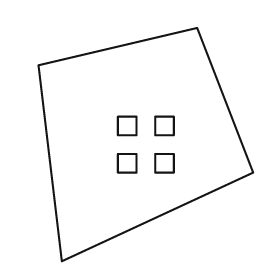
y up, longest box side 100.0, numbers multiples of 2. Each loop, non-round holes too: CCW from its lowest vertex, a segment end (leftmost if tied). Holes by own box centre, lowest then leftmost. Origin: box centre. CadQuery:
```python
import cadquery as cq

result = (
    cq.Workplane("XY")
    .moveTo(-36.0, -50.0)
    .lineTo(46.0, -12.0)
    .lineTo(22.0, 50.0)
    .lineTo(-46.0, 34.0)
    .close()
    .moveTo(-12.0, -12.0)
    .lineTo(-4.0, -12.0)
    .lineTo(-4.0, -4.0)
    .lineTo(-12.0, -4.0)
    .close()
    .moveTo(4.0, -12.0)
    .lineTo(12.0, -12.0)
    .lineTo(12.0, -4.0)
    .lineTo(4.0, -4.0)
    .close()
    .moveTo(-12.0, 4.0)
    .lineTo(-4.0, 4.0)
    .lineTo(-4.0, 12.0)
    .lineTo(-12.0, 12.0)
    .close()
    .moveTo(4.0, 4.0)
    .lineTo(12.0, 4.0)
    .lineTo(12.0, 12.0)
    .lineTo(4.0, 12.0)
    .close()
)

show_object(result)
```